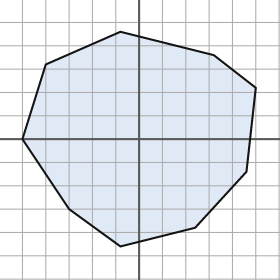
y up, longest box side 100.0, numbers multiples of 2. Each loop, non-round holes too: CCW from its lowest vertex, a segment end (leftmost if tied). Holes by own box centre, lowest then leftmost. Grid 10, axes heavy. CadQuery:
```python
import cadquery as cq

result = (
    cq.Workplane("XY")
    .moveTo(-8.0, -46.0)
    .lineTo(24.0, -38.0)
    .lineTo(46.0, -14.0)
    .lineTo(50.0, 22.0)
    .lineTo(32.0, 36.0)
    .lineTo(-8.0, 46.0)
    .lineTo(-40.0, 32.0)
    .lineTo(-50.0, 0.0)
    .lineTo(-30.0, -30.0)
    .close()
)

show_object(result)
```